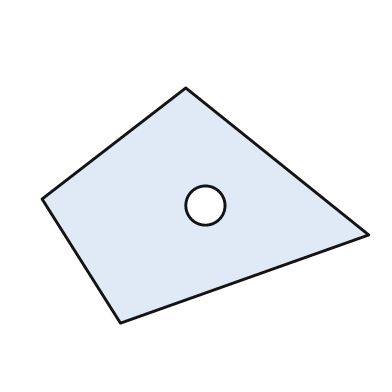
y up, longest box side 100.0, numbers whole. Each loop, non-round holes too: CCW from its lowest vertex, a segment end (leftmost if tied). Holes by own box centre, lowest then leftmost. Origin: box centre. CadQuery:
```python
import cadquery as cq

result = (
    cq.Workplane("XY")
    .moveTo(-26.0, -36.0)
    .lineTo(50.0, -9.0)
    .lineTo(-6.0, 36.0)
    .lineTo(-50.0, 2.0)
    .close()
    .moveTo(0.0, 0.0)
    .circle(6.0)
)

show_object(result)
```